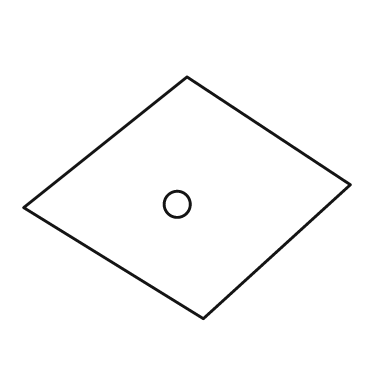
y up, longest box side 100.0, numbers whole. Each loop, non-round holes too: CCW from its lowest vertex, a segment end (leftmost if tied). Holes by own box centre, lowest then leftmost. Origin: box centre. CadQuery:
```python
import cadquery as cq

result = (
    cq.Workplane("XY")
    .moveTo(5.0, -37.0)
    .lineTo(50.0, 4.0)
    .lineTo(0.0, 37.0)
    .lineTo(-50.0, -3.0)
    .close()
    .moveTo(-3.0, -2.0)
    .circle(4.0)
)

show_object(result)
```